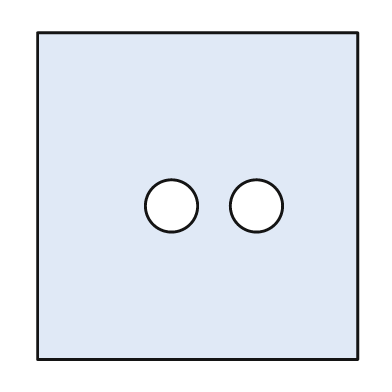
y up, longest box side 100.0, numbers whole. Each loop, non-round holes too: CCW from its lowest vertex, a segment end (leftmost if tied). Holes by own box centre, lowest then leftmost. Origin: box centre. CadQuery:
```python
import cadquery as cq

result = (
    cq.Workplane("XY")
    .moveTo(-49.0, -50.0)
    .lineTo(49.0, -50.0)
    .lineTo(49.0, 50.0)
    .lineTo(-49.0, 50.0)
    .close()
    .moveTo(-8.0, -3.0)
    .circle(8.0)
    .moveTo(18.0, -3.0)
    .circle(8.0)
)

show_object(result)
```